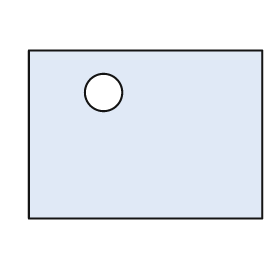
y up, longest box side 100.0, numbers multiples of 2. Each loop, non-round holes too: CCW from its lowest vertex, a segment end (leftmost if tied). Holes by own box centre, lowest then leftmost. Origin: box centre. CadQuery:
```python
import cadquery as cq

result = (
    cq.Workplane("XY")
    .moveTo(-50.0, -36.0)
    .lineTo(50.0, -36.0)
    .lineTo(50.0, 36.0)
    .lineTo(-50.0, 36.0)
    .close()
    .moveTo(-18.0, 18.0)
    .circle(8.0)
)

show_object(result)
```